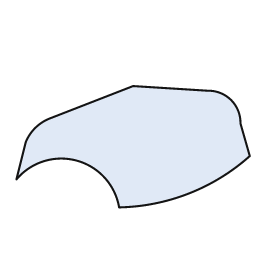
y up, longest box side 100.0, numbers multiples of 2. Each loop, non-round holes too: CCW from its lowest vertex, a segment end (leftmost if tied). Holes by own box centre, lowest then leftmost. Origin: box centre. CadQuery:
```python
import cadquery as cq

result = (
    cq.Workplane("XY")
    .moveTo(-6.0, -26.0)
    .threePointArc((24.0, -20.0), (50.0, -4.0))
    .lineTo(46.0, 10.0)
    .threePointArc((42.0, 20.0), (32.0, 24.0))
    .lineTo(0.0, 26.0)
    .lineTo(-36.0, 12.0)
    .threePointArc((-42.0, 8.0), (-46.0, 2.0))
    .lineTo(-50.0, -14.0)
    .threePointArc((-24.0, -6.0), (-6.0, -26.0))
    .close()
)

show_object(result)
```